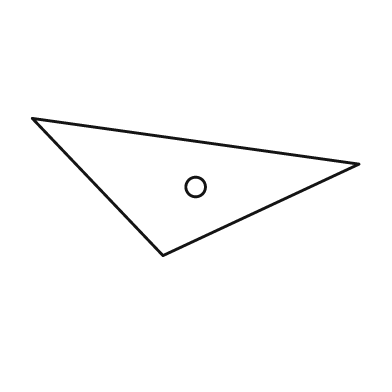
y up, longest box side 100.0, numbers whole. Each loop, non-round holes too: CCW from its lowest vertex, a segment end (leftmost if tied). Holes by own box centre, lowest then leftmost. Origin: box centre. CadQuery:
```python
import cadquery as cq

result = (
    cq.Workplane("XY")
    .moveTo(-10.0, -21.0)
    .lineTo(50.0, 7.0)
    .lineTo(-50.0, 21.0)
    .close()
    .moveTo(0.0, 0.0)
    .circle(3.0)
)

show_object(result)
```